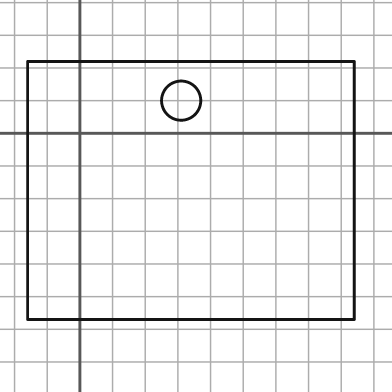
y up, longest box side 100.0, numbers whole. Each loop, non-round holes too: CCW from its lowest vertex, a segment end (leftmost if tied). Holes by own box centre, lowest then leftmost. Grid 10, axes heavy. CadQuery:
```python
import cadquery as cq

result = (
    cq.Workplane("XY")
    .moveTo(-16.0, -57.0)
    .lineTo(84.0, -57.0)
    .lineTo(84.0, 22.0)
    .lineTo(-16.0, 22.0)
    .close()
    .moveTo(31.0, 10.0)
    .circle(6.0)
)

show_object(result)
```